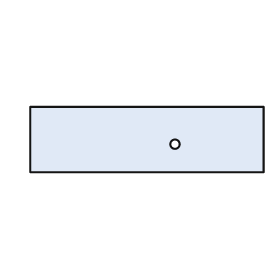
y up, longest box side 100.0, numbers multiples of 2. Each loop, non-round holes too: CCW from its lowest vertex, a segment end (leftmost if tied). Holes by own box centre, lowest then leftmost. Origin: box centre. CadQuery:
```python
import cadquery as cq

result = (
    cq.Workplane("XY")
    .moveTo(-50.0, -14.0)
    .lineTo(50.0, -14.0)
    .lineTo(50.0, 14.0)
    .lineTo(-50.0, 14.0)
    .close()
    .moveTo(12.0, -2.0)
    .circle(2.0)
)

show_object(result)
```